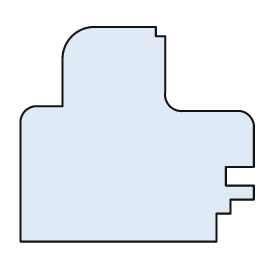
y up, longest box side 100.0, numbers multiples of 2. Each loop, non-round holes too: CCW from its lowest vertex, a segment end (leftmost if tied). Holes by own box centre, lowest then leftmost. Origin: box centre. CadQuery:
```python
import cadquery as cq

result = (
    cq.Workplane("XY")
    .moveTo(-50.0, -46.0)
    .lineTo(34.0, -46.0)
    .lineTo(34.0, -34.0)
    .lineTo(40.0, -34.0)
    .lineTo(40.0, -28.0)
    .lineTo(50.0, -28.0)
    .lineTo(50.0, -22.0)
    .lineTo(38.0, -22.0)
    .lineTo(38.0, -14.0)
    .lineTo(50.0, -14.0)
    .lineTo(50.0, 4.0)
    .threePointArc((48.0, 8.0), (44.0, 10.0))
    .lineTo(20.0, 10.0)
    .threePointArc((14.0, 12.0), (12.0, 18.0))
    .lineTo(12.0, 42.0)
    .lineTo(8.0, 42.0)
    .lineTo(8.0, 46.0)
    .lineTo(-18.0, 46.0)
    .threePointArc((-28.0, 42.0), (-32.0, 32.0))
    .lineTo(-32.0, 12.0)
    .lineTo(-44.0, 12.0)
    .threePointArc((-48.0, 10.0), (-50.0, 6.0))
    .close()
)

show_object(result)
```